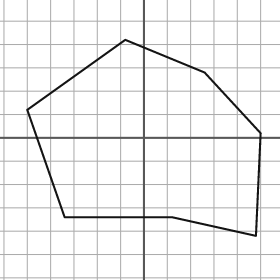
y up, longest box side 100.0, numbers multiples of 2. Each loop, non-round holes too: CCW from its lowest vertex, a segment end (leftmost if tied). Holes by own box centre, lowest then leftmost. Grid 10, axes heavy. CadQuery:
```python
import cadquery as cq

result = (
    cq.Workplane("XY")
    .moveTo(48.0, -42.0)
    .lineTo(50.0, 2.0)
    .lineTo(26.0, 28.0)
    .lineTo(-8.0, 42.0)
    .lineTo(-50.0, 12.0)
    .lineTo(-34.0, -34.0)
    .lineTo(12.0, -34.0)
    .close()
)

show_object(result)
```